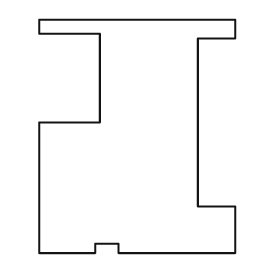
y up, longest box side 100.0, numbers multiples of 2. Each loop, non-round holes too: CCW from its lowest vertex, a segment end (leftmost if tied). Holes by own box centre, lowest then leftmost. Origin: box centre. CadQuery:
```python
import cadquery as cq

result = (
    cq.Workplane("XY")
    .moveTo(-42.0, -50.0)
    .lineTo(-18.0, -50.0)
    .lineTo(-18.0, -46.0)
    .lineTo(-8.0, -46.0)
    .lineTo(-8.0, -50.0)
    .lineTo(42.0, -50.0)
    .lineTo(42.0, -30.0)
    .lineTo(26.0, -30.0)
    .lineTo(26.0, 42.0)
    .lineTo(42.0, 42.0)
    .lineTo(42.0, 50.0)
    .lineTo(-42.0, 50.0)
    .lineTo(-42.0, 44.0)
    .lineTo(-16.0, 44.0)
    .lineTo(-16.0, 6.0)
    .lineTo(-42.0, 6.0)
    .close()
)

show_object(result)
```